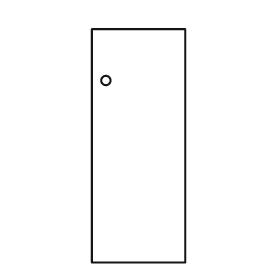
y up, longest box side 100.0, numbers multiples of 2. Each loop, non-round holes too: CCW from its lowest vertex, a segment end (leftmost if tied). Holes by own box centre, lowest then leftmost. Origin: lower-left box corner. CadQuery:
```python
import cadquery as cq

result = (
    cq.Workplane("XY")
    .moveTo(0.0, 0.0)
    .lineTo(40.0, 0.0)
    .lineTo(40.0, 100.0)
    .lineTo(0.0, 100.0)
    .close()
    .moveTo(6.0, 78.0)
    .circle(2.0)
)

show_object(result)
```